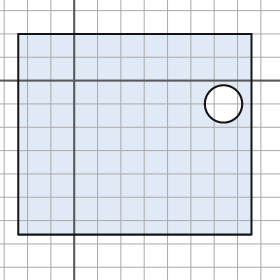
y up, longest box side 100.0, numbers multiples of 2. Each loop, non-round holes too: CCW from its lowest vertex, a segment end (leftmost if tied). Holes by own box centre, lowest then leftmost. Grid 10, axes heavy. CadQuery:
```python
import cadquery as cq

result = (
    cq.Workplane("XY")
    .moveTo(-24.0, -66.0)
    .lineTo(76.0, -66.0)
    .lineTo(76.0, 20.0)
    .lineTo(-24.0, 20.0)
    .close()
    .moveTo(64.0, -10.0)
    .circle(8.0)
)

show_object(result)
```